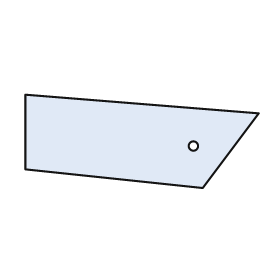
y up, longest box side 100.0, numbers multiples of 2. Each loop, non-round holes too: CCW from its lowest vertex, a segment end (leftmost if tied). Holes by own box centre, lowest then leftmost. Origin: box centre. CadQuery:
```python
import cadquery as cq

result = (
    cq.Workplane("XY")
    .moveTo(26.0, -20.0)
    .lineTo(50.0, 12.0)
    .lineTo(-50.0, 20.0)
    .lineTo(-50.0, -12.0)
    .close()
    .moveTo(22.0, -2.0)
    .circle(2.0)
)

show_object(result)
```